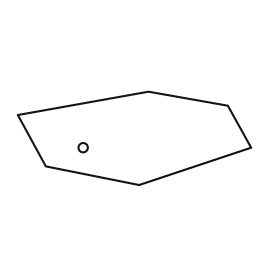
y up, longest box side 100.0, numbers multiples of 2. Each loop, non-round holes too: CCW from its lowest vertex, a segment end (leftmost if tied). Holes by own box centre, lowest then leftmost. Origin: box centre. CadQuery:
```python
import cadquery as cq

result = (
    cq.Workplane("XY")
    .moveTo(2.0, -20.0)
    .lineTo(50.0, -4.0)
    .lineTo(40.0, 14.0)
    .lineTo(6.0, 20.0)
    .lineTo(-50.0, 10.0)
    .lineTo(-38.0, -12.0)
    .close()
    .moveTo(-22.0, -4.0)
    .circle(2.0)
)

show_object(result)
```